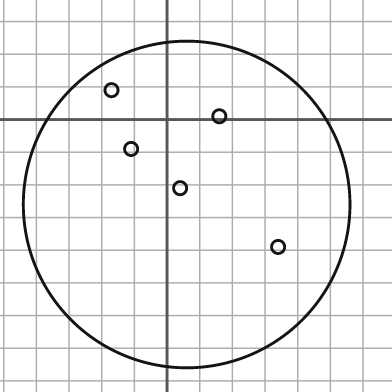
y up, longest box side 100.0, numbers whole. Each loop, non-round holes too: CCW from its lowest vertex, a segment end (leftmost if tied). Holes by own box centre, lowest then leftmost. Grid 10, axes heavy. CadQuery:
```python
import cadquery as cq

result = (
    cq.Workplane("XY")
    .moveTo(6.0, -26.0)
    .circle(50.0)
    .moveTo(34.0, -39.0)
    .circle(2.0)
    .moveTo(4.0, -21.0)
    .circle(2.0)
    .moveTo(-11.0, -9.0)
    .circle(2.0)
    .moveTo(16.0, 1.0)
    .circle(2.0)
    .moveTo(-17.0, 9.0)
    .circle(2.0)
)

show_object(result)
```